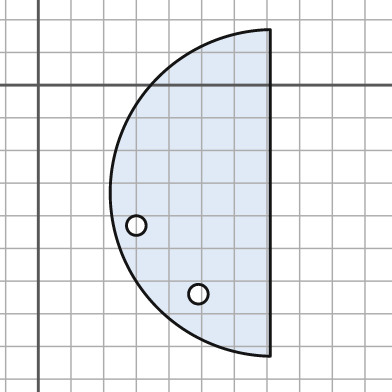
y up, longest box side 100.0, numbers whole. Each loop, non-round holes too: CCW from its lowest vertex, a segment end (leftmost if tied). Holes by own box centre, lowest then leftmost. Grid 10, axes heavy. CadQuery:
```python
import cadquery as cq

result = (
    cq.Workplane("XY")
    .moveTo(71.0, -83.0)
    .lineTo(71.0, 17.0)
    .threePointArc((22.0, -33.0), (71.0, -83.0))
    .close()
    .moveTo(49.0, -64.0)
    .circle(3.0)
    .moveTo(30.0, -43.0)
    .circle(3.0)
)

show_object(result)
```